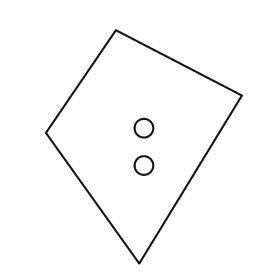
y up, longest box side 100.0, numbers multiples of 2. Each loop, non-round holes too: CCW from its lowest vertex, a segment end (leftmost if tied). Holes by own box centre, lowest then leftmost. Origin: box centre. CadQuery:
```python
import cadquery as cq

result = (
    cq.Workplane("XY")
    .moveTo(-2.0, -50.0)
    .lineTo(42.0, 22.0)
    .lineTo(-12.0, 50.0)
    .lineTo(-42.0, 6.0)
    .close()
    .moveTo(0.0, -8.0)
    .circle(4.0)
    .moveTo(0.0, 8.0)
    .circle(4.0)
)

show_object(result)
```